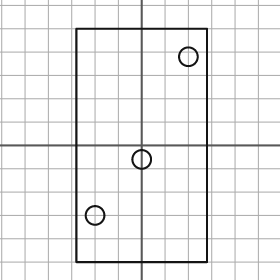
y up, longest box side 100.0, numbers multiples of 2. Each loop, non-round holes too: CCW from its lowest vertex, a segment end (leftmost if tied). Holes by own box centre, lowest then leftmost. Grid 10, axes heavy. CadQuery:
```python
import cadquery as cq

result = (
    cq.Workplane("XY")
    .moveTo(-28.0, -50.0)
    .lineTo(28.0, -50.0)
    .lineTo(28.0, 50.0)
    .lineTo(-28.0, 50.0)
    .close()
    .moveTo(-20.0, -30.0)
    .circle(4.0)
    .moveTo(0.0, -6.0)
    .circle(4.0)
    .moveTo(20.0, 38.0)
    .circle(4.0)
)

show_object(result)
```